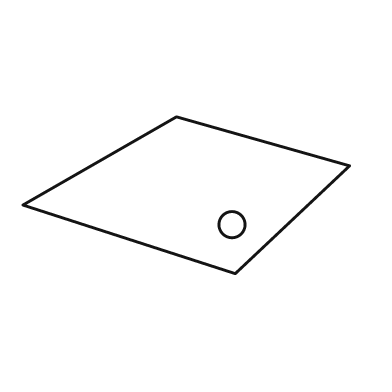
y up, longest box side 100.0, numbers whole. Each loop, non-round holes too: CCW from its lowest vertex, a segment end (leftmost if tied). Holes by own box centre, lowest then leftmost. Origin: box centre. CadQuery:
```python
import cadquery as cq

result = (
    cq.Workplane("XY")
    .moveTo(15.0, -24.0)
    .lineTo(50.0, 9.0)
    .lineTo(-3.0, 24.0)
    .lineTo(-50.0, -3.0)
    .close()
    .moveTo(14.0, -9.0)
    .circle(4.0)
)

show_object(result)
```